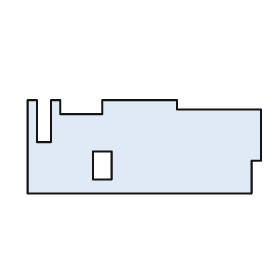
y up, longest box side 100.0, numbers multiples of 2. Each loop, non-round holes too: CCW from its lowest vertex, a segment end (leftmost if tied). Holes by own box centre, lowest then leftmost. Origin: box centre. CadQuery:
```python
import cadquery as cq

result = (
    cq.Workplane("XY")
    .moveTo(-50.0, -20.0)
    .lineTo(46.0, -20.0)
    .lineTo(46.0, -6.0)
    .lineTo(50.0, -6.0)
    .lineTo(50.0, 16.0)
    .lineTo(14.0, 16.0)
    .lineTo(14.0, 20.0)
    .lineTo(-18.0, 20.0)
    .lineTo(-18.0, 14.0)
    .lineTo(-36.0, 14.0)
    .lineTo(-36.0, 20.0)
    .lineTo(-40.0, 20.0)
    .lineTo(-40.0, 2.0)
    .lineTo(-46.0, 2.0)
    .lineTo(-46.0, 20.0)
    .lineTo(-50.0, 20.0)
    .close()
    .moveTo(-22.0, -14.0)
    .lineTo(-14.0, -14.0)
    .lineTo(-14.0, -2.0)
    .lineTo(-22.0, -2.0)
    .close()
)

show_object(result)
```